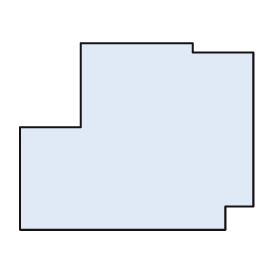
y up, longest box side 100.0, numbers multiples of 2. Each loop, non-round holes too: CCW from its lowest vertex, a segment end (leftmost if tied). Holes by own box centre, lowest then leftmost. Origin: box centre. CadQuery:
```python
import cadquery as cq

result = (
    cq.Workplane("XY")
    .moveTo(-50.0, -40.0)
    .lineTo(38.0, -40.0)
    .lineTo(38.0, -30.0)
    .lineTo(50.0, -30.0)
    .lineTo(50.0, 36.0)
    .lineTo(24.0, 36.0)
    .lineTo(24.0, 40.0)
    .lineTo(-24.0, 40.0)
    .lineTo(-24.0, 4.0)
    .lineTo(-50.0, 4.0)
    .close()
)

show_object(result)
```